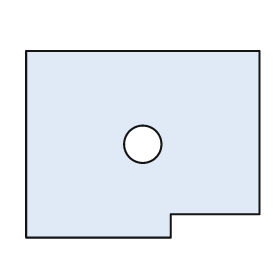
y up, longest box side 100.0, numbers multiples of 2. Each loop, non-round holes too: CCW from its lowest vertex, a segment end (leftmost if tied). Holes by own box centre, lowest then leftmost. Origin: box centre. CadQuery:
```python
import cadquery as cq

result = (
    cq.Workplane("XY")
    .moveTo(-50.0, -40.0)
    .lineTo(12.0, -40.0)
    .lineTo(12.0, -30.0)
    .lineTo(50.0, -30.0)
    .lineTo(50.0, 40.0)
    .lineTo(-50.0, 40.0)
    .close()
    .moveTo(0.0, 0.0)
    .circle(8.0)
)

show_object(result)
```